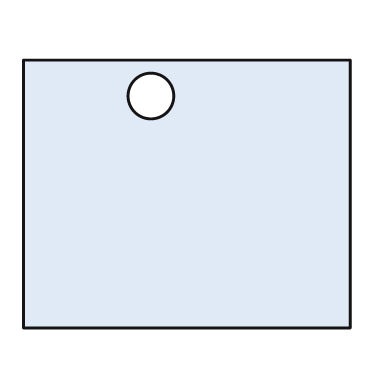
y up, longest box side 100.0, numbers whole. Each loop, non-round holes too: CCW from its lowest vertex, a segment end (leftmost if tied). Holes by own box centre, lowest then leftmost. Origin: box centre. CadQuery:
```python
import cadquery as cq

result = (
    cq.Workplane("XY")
    .moveTo(-50.0, -41.0)
    .lineTo(50.0, -41.0)
    .lineTo(50.0, 41.0)
    .lineTo(-50.0, 41.0)
    .close()
    .moveTo(-11.0, 30.0)
    .circle(7.0)
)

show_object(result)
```